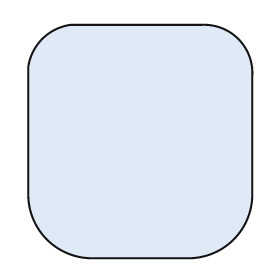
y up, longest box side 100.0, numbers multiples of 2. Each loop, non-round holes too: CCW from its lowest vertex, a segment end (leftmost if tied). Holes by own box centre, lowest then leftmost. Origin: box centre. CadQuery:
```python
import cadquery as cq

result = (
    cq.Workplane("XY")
    .moveTo(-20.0, -50.0)
    .lineTo(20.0, -50.0)
    .threePointArc((40.0, -42.0), (48.0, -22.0))
    .lineTo(48.0, 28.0)
    .threePointArc((42.0, 44.0), (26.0, 50.0))
    .lineTo(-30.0, 50.0)
    .threePointArc((-42.0, 44.0), (-48.0, 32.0))
    .lineTo(-48.0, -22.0)
    .threePointArc((-40.0, -42.0), (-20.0, -50.0))
    .close()
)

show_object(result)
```